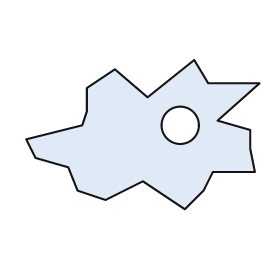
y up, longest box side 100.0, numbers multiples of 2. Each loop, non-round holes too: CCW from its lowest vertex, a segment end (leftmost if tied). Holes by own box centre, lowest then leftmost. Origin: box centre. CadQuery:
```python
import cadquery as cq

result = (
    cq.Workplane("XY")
    .moveTo(18.0, -32.0)
    .lineTo(26.0, -24.0)
    .lineTo(30.0, -16.0)
    .lineTo(48.0, -16.0)
    .lineTo(46.0, -6.0)
    .lineTo(46.0, 2.0)
    .lineTo(32.0, 6.0)
    .lineTo(50.0, 22.0)
    .lineTo(28.0, 22.0)
    .lineTo(22.0, 32.0)
    .lineTo(2.0, 16.0)
    .lineTo(-12.0, 28.0)
    .lineTo(-24.0, 20.0)
    .lineTo(-24.0, 10.0)
    .lineTo(-26.0, 4.0)
    .lineTo(-50.0, -2.0)
    .lineTo(-46.0, -10.0)
    .lineTo(-32.0, -14.0)
    .lineTo(-28.0, -24.0)
    .lineTo(-16.0, -28.0)
    .lineTo(0.0, -20.0)
    .close()
    .moveTo(16.0, 4.0)
    .circle(8.0)
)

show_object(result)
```